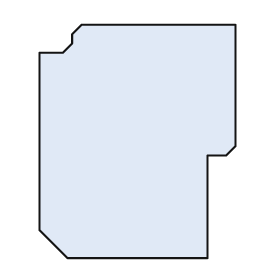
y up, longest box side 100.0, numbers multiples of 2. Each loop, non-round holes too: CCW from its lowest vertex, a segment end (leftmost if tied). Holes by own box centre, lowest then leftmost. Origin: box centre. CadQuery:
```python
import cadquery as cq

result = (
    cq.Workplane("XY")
    .moveTo(-30.0, -50.0)
    .lineTo(30.0, -50.0)
    .lineTo(30.0, -6.0)
    .lineTo(38.0, -6.0)
    .lineTo(42.0, -2.0)
    .lineTo(42.0, 50.0)
    .lineTo(-24.0, 50.0)
    .lineTo(-28.0, 46.0)
    .lineTo(-28.0, 42.0)
    .lineTo(-32.0, 38.0)
    .lineTo(-42.0, 38.0)
    .lineTo(-42.0, -38.0)
    .close()
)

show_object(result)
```